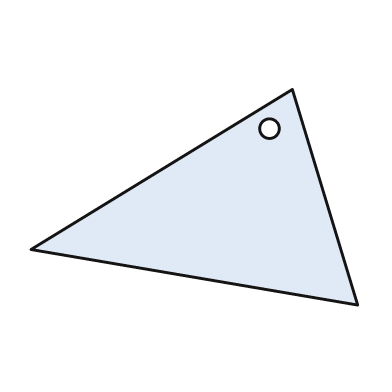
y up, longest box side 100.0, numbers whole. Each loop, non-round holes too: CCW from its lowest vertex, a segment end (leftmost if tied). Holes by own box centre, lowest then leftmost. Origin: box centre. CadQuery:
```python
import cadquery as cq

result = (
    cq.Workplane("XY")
    .moveTo(50.0, -33.0)
    .lineTo(30.0, 33.0)
    .lineTo(-50.0, -16.0)
    .close()
    .moveTo(23.0, 21.0)
    .circle(3.0)
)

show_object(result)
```